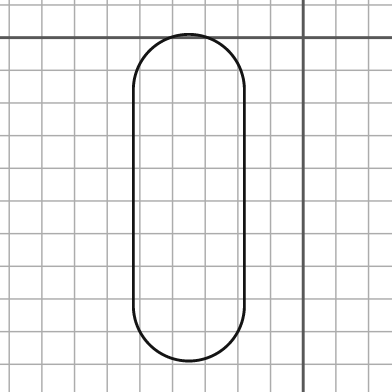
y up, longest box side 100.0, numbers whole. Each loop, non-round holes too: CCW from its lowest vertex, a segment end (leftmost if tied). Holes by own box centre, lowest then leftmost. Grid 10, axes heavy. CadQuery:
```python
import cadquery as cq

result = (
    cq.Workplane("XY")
    .moveTo(-52.0, -82.0)
    .threePointArc((-35.0, -99.0), (-18.0, -82.0))
    .lineTo(-18.0, -16.0)
    .threePointArc((-35.0, 1.0), (-52.0, -16.0))
    .close()
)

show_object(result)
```